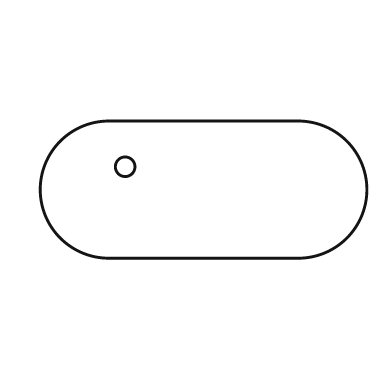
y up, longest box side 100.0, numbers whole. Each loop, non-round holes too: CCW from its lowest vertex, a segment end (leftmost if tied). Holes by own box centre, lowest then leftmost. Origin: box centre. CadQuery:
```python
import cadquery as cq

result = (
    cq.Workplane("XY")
    .moveTo(-29.0, -21.0)
    .lineTo(29.0, -21.0)
    .threePointArc((50.0, 0.0), (29.0, 21.0))
    .lineTo(-29.0, 21.0)
    .threePointArc((-50.0, 0.0), (-29.0, -21.0))
    .close()
    .moveTo(-24.0, 7.0)
    .circle(3.0)
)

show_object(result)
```